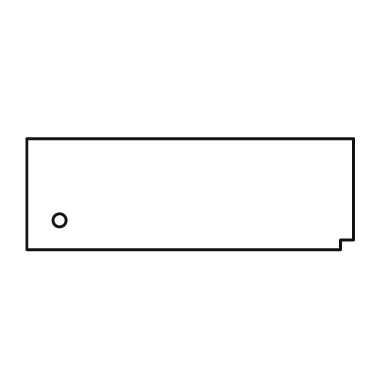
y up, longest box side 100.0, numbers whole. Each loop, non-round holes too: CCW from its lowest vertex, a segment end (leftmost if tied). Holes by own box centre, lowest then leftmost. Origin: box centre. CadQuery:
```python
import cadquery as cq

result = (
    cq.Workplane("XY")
    .moveTo(-50.0, -17.0)
    .lineTo(46.0, -17.0)
    .lineTo(46.0, -14.0)
    .lineTo(50.0, -14.0)
    .lineTo(50.0, 17.0)
    .lineTo(-50.0, 17.0)
    .close()
    .moveTo(-40.0, -8.0)
    .circle(2.0)
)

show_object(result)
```